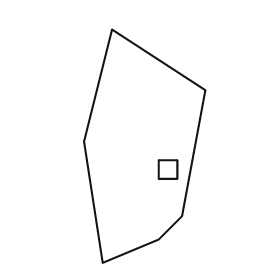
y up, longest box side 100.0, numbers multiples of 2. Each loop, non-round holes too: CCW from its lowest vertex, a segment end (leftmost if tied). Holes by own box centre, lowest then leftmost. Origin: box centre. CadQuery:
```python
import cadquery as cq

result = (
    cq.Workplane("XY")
    .moveTo(-18.0, -50.0)
    .lineTo(6.0, -40.0)
    .lineTo(16.0, -30.0)
    .lineTo(26.0, 24.0)
    .lineTo(-14.0, 50.0)
    .lineTo(-26.0, 2.0)
    .close()
    .moveTo(6.0, -14.0)
    .lineTo(14.0, -14.0)
    .lineTo(14.0, -6.0)
    .lineTo(6.0, -6.0)
    .close()
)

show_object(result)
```